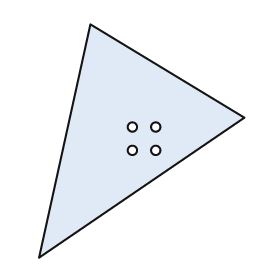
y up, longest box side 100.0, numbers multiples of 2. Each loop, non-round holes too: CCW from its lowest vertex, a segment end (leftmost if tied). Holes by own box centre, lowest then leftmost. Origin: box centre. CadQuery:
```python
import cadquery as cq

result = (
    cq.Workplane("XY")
    .moveTo(-44.0, -50.0)
    .lineTo(44.0, 10.0)
    .lineTo(-22.0, 50.0)
    .close()
    .moveTo(-4.0, -4.0)
    .circle(2.0)
    .moveTo(6.0, -4.0)
    .circle(2.0)
    .moveTo(-4.0, 6.0)
    .circle(2.0)
    .moveTo(6.0, 6.0)
    .circle(2.0)
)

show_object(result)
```